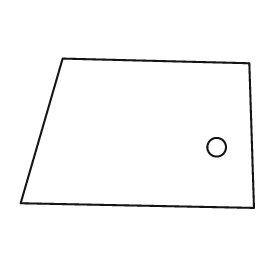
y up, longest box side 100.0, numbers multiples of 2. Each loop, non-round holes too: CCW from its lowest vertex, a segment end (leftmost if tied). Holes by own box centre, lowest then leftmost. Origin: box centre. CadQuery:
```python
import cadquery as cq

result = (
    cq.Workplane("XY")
    .moveTo(50.0, -32.0)
    .lineTo(48.0, 30.0)
    .lineTo(-32.0, 32.0)
    .lineTo(-50.0, -30.0)
    .close()
    .moveTo(34.0, -6.0)
    .circle(4.0)
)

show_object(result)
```